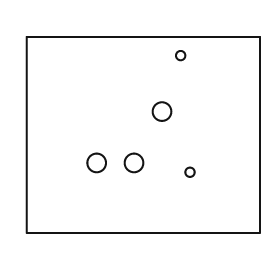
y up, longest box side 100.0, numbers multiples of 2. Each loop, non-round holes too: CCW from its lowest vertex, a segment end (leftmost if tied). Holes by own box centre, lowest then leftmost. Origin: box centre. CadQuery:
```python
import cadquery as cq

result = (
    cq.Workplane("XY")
    .moveTo(-50.0, -42.0)
    .lineTo(50.0, -42.0)
    .lineTo(50.0, 42.0)
    .lineTo(-50.0, 42.0)
    .close()
    .moveTo(20.0, -16.0)
    .circle(2.0)
    .moveTo(-20.0, -12.0)
    .circle(4.0)
    .moveTo(-4.0, -12.0)
    .circle(4.0)
    .moveTo(8.0, 10.0)
    .circle(4.0)
    .moveTo(16.0, 34.0)
    .circle(2.0)
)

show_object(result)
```